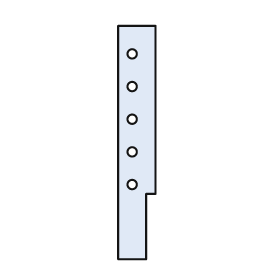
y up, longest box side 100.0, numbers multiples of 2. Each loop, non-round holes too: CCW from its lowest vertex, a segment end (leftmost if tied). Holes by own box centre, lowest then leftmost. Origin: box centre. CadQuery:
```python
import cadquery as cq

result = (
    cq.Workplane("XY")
    .moveTo(-8.0, -50.0)
    .lineTo(4.0, -50.0)
    .lineTo(4.0, -22.0)
    .lineTo(8.0, -22.0)
    .lineTo(8.0, 50.0)
    .lineTo(-8.0, 50.0)
    .close()
    .moveTo(-2.0, -18.0)
    .circle(2.0)
    .moveTo(-2.0, -4.0)
    .circle(2.0)
    .moveTo(-2.0, 10.0)
    .circle(2.0)
    .moveTo(-2.0, 24.0)
    .circle(2.0)
    .moveTo(-2.0, 38.0)
    .circle(2.0)
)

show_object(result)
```